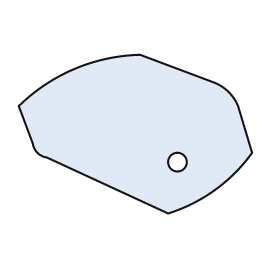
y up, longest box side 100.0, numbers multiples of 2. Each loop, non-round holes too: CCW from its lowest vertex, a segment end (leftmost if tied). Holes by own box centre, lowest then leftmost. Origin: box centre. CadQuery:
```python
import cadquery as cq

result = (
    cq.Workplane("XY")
    .moveTo(14.0, -34.0)
    .threePointArc((34.0, -24.0), (50.0, -8.0))
    .lineTo(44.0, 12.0)
    .threePointArc((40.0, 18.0), (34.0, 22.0))
    .lineTo(2.0, 34.0)
    .threePointArc((-26.0, 28.0), (-50.0, 12.0))
    .lineTo(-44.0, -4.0)
    .threePointArc((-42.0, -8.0), (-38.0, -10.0))
    .close()
    .moveTo(18.0, -12.0)
    .circle(4.0)
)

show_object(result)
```